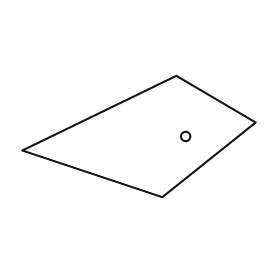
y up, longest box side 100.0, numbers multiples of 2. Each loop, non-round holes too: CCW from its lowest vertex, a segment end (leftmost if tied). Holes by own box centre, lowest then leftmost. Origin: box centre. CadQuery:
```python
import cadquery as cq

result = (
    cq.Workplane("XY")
    .moveTo(10.0, -26.0)
    .lineTo(50.0, 6.0)
    .lineTo(16.0, 26.0)
    .lineTo(-50.0, -6.0)
    .close()
    .moveTo(20.0, 0.0)
    .circle(2.0)
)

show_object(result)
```